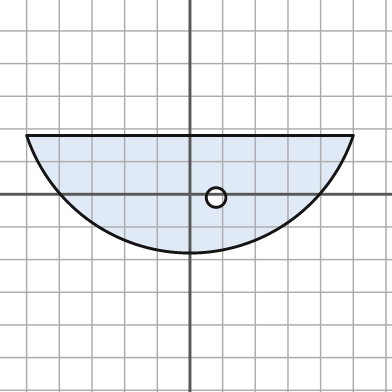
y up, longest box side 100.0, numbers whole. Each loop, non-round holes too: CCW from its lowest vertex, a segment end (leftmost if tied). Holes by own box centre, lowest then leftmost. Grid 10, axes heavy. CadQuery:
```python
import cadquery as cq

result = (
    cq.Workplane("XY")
    .moveTo(-50.0, 18.0)
    .threePointArc((0.0, -18.0), (50.0, 18.0))
    .close()
    .moveTo(8.0, -1.0)
    .circle(3.0)
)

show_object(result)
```